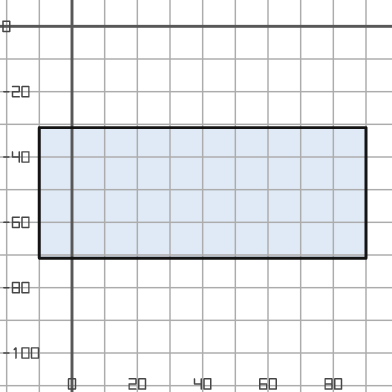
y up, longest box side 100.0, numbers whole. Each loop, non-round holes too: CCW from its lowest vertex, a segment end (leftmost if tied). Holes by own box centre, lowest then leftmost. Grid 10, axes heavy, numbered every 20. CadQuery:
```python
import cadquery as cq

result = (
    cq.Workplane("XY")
    .moveTo(-10.0, -71.0)
    .lineTo(90.0, -71.0)
    .lineTo(90.0, -31.0)
    .lineTo(-10.0, -31.0)
    .close()
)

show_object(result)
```